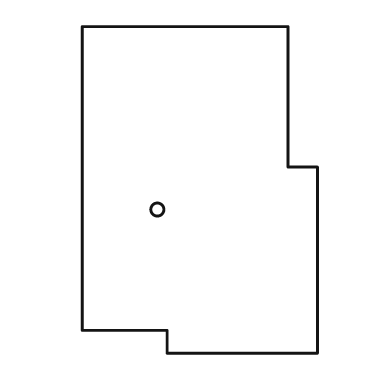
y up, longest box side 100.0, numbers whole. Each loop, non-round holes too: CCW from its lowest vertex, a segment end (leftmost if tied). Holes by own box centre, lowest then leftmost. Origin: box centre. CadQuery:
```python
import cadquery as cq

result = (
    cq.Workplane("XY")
    .moveTo(-10.0, -50.0)
    .lineTo(36.0, -50.0)
    .lineTo(36.0, 7.0)
    .lineTo(27.0, 7.0)
    .lineTo(27.0, 50.0)
    .lineTo(-36.0, 50.0)
    .lineTo(-36.0, -43.0)
    .lineTo(-10.0, -43.0)
    .close()
    .moveTo(-13.0, -6.0)
    .circle(2.0)
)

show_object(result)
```